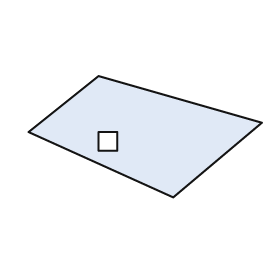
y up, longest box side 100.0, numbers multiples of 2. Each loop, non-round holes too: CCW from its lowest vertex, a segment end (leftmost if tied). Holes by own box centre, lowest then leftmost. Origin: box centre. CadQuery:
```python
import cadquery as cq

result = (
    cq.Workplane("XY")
    .moveTo(12.0, -26.0)
    .lineTo(50.0, 6.0)
    .lineTo(-20.0, 26.0)
    .lineTo(-50.0, 2.0)
    .close()
    .moveTo(-20.0, -6.0)
    .lineTo(-12.0, -6.0)
    .lineTo(-12.0, 2.0)
    .lineTo(-20.0, 2.0)
    .close()
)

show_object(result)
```